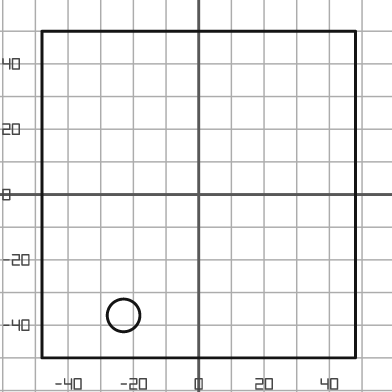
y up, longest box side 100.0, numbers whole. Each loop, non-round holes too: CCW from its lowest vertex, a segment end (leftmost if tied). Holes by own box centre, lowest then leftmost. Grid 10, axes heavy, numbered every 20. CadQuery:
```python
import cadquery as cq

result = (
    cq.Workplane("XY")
    .moveTo(-48.0, -50.0)
    .lineTo(48.0, -50.0)
    .lineTo(48.0, 50.0)
    .lineTo(-48.0, 50.0)
    .close()
    .moveTo(-23.0, -37.0)
    .circle(5.0)
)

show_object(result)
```